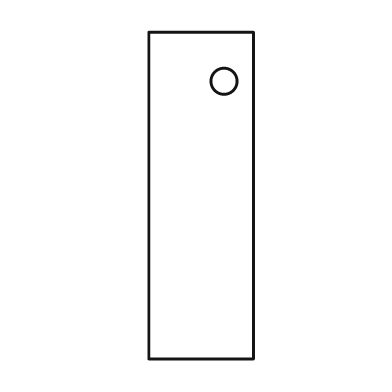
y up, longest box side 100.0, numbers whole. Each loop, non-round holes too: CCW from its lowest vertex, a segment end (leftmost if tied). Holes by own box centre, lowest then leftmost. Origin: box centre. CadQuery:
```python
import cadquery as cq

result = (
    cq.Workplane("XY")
    .moveTo(-16.0, -50.0)
    .lineTo(16.0, -50.0)
    .lineTo(16.0, 50.0)
    .lineTo(-16.0, 50.0)
    .close()
    .moveTo(7.0, 35.0)
    .circle(4.0)
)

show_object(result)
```